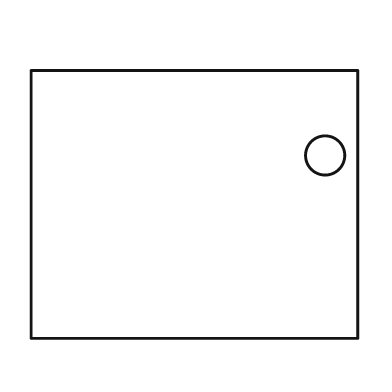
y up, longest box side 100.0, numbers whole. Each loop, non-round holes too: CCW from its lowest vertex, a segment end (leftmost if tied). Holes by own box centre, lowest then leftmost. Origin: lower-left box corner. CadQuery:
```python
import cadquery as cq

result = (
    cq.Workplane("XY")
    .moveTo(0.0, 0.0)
    .lineTo(100.0, 0.0)
    .lineTo(100.0, 82.0)
    .lineTo(0.0, 82.0)
    .close()
    .moveTo(90.0, 56.0)
    .circle(6.0)
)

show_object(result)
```